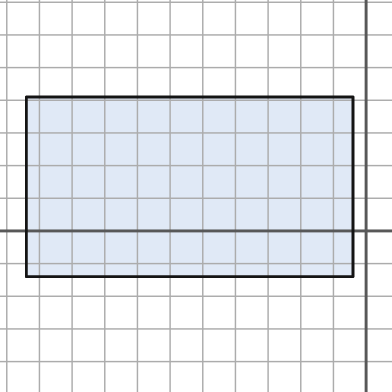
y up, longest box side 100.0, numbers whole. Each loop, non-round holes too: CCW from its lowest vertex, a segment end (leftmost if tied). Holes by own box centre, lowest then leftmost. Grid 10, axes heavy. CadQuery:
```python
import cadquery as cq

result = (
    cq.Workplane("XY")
    .moveTo(-104.0, -14.0)
    .lineTo(-4.0, -14.0)
    .lineTo(-4.0, 41.0)
    .lineTo(-104.0, 41.0)
    .close()
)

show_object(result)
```